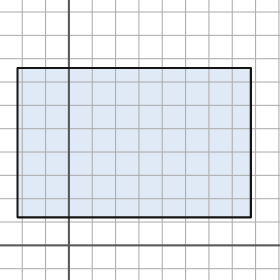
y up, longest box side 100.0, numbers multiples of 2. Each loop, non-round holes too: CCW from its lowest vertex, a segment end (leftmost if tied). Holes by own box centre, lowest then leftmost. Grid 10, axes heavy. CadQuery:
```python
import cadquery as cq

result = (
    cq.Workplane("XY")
    .moveTo(-22.0, 12.0)
    .lineTo(78.0, 12.0)
    .lineTo(78.0, 76.0)
    .lineTo(-22.0, 76.0)
    .close()
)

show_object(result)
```